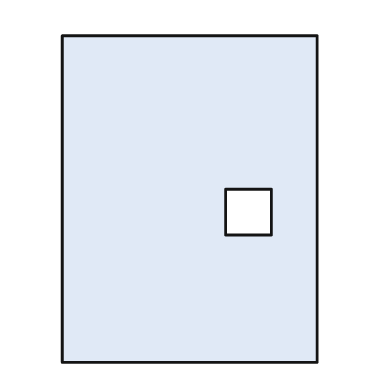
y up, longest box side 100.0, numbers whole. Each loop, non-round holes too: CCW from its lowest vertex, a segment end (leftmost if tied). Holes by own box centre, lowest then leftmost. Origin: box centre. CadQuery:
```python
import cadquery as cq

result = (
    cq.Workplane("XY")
    .moveTo(-39.0, -50.0)
    .lineTo(39.0, -50.0)
    .lineTo(39.0, 50.0)
    .lineTo(-39.0, 50.0)
    .close()
    .moveTo(11.0, -11.0)
    .lineTo(25.0, -11.0)
    .lineTo(25.0, 3.0)
    .lineTo(11.0, 3.0)
    .close()
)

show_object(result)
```